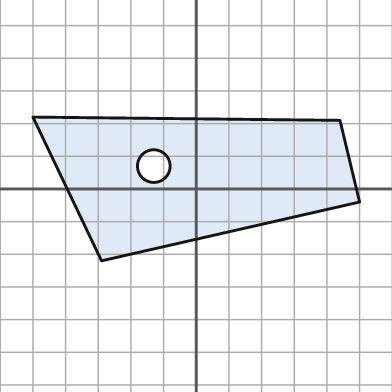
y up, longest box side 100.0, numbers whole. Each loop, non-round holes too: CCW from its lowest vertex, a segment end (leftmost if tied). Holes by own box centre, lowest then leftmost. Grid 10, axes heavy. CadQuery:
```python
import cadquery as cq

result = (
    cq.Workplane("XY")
    .moveTo(-29.0, -22.0)
    .lineTo(50.0, -4.0)
    .lineTo(44.0, 21.0)
    .lineTo(-50.0, 22.0)
    .close()
    .moveTo(-13.0, 7.0)
    .circle(5.0)
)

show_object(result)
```